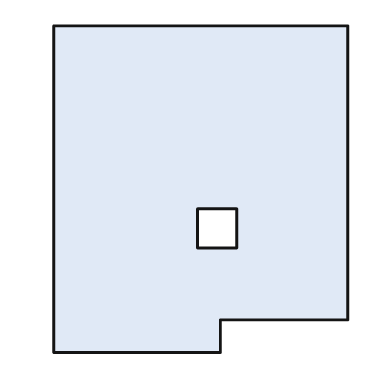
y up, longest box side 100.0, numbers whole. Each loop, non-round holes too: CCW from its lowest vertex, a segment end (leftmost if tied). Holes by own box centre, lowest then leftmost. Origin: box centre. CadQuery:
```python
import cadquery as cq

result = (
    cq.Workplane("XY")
    .moveTo(-45.0, -50.0)
    .lineTo(6.0, -50.0)
    .lineTo(6.0, -40.0)
    .lineTo(45.0, -40.0)
    .lineTo(45.0, 50.0)
    .lineTo(-45.0, 50.0)
    .close()
    .moveTo(-1.0, -18.0)
    .lineTo(11.0, -18.0)
    .lineTo(11.0, -6.0)
    .lineTo(-1.0, -6.0)
    .close()
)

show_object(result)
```